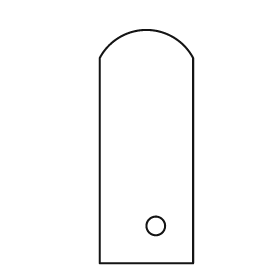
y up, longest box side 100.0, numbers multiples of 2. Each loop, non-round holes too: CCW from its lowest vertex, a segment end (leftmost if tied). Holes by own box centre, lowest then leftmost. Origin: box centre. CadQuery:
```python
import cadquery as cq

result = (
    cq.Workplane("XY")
    .moveTo(-20.0, -50.0)
    .lineTo(20.0, -50.0)
    .lineTo(20.0, 38.0)
    .threePointArc((0.0, 50.0), (-20.0, 38.0))
    .close()
    .moveTo(4.0, -34.0)
    .circle(4.0)
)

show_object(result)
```